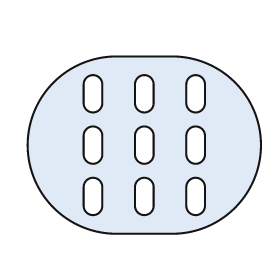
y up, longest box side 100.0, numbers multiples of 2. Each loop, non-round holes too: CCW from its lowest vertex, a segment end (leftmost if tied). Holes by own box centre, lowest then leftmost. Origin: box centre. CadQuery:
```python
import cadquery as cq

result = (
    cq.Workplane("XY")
    .moveTo(-12.0, -38.0)
    .lineTo(12.0, -38.0)
    .threePointArc((50.0, 0.0), (12.0, 38.0))
    .lineTo(-12.0, 38.0)
    .threePointArc((-50.0, 0.0), (-12.0, -38.0))
    .close()
    .moveTo(-26.0, -26.0)
    .threePointArc((-22.0, -30.0), (-18.0, -26.0))
    .lineTo(-18.0, -18.0)
    .threePointArc((-22.0, -14.0), (-26.0, -18.0))
    .close()
    .moveTo(-4.0, -26.0)
    .threePointArc((0.0, -30.0), (4.0, -26.0))
    .lineTo(4.0, -18.0)
    .threePointArc((0.0, -14.0), (-4.0, -18.0))
    .close()
    .moveTo(18.0, -26.0)
    .threePointArc((22.0, -30.0), (26.0, -26.0))
    .lineTo(26.0, -18.0)
    .threePointArc((22.0, -14.0), (18.0, -18.0))
    .close()
    .moveTo(-26.0, -4.0)
    .threePointArc((-22.0, -8.0), (-18.0, -4.0))
    .lineTo(-18.0, 4.0)
    .threePointArc((-22.0, 8.0), (-26.0, 4.0))
    .close()
    .moveTo(-4.0, -4.0)
    .threePointArc((0.0, -8.0), (4.0, -4.0))
    .lineTo(4.0, 4.0)
    .threePointArc((0.0, 8.0), (-4.0, 4.0))
    .close()
    .moveTo(18.0, -4.0)
    .threePointArc((22.0, -8.0), (26.0, -4.0))
    .lineTo(26.0, 4.0)
    .threePointArc((22.0, 8.0), (18.0, 4.0))
    .close()
    .moveTo(-26.0, 18.0)
    .threePointArc((-22.0, 14.0), (-18.0, 18.0))
    .lineTo(-18.0, 26.0)
    .threePointArc((-22.0, 30.0), (-26.0, 26.0))
    .close()
    .moveTo(-4.0, 18.0)
    .threePointArc((0.0, 14.0), (4.0, 18.0))
    .lineTo(4.0, 26.0)
    .threePointArc((0.0, 30.0), (-4.0, 26.0))
    .close()
    .moveTo(18.0, 18.0)
    .threePointArc((22.0, 14.0), (26.0, 18.0))
    .lineTo(26.0, 26.0)
    .threePointArc((22.0, 30.0), (18.0, 26.0))
    .close()
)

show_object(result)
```